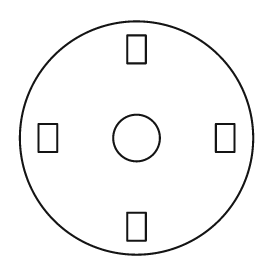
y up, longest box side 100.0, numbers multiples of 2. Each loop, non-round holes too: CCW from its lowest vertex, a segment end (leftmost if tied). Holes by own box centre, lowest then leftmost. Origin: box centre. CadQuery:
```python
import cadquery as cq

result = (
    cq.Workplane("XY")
    .moveTo(0.0, 0.0)
    .circle(50.0)
    .moveTo(-4.0, -44.0)
    .lineTo(4.0, -44.0)
    .lineTo(4.0, -32.0)
    .lineTo(-4.0, -32.0)
    .close()
    .moveTo(-42.0, -6.0)
    .lineTo(-34.0, -6.0)
    .lineTo(-34.0, 6.0)
    .lineTo(-42.0, 6.0)
    .close()
    .moveTo(0.0, 0.0)
    .circle(10.0)
    .moveTo(34.0, -6.0)
    .lineTo(42.0, -6.0)
    .lineTo(42.0, 6.0)
    .lineTo(34.0, 6.0)
    .close()
    .moveTo(-4.0, 32.0)
    .lineTo(4.0, 32.0)
    .lineTo(4.0, 44.0)
    .lineTo(-4.0, 44.0)
    .close()
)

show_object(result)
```